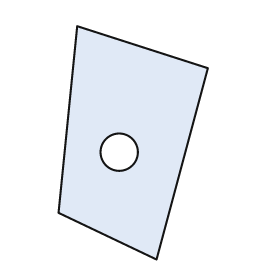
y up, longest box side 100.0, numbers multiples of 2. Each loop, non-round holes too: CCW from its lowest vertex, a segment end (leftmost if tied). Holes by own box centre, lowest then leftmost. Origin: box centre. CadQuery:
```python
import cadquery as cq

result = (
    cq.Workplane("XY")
    .moveTo(10.0, -50.0)
    .lineTo(32.0, 32.0)
    .lineTo(-24.0, 50.0)
    .lineTo(-32.0, -30.0)
    .close()
    .moveTo(-6.0, -4.0)
    .circle(8.0)
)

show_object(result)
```